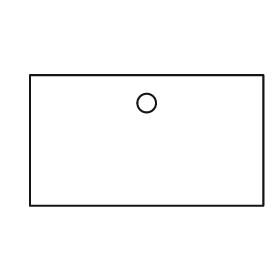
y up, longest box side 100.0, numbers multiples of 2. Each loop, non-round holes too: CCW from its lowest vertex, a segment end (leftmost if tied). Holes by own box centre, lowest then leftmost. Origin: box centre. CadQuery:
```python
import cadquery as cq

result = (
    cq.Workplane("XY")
    .moveTo(-50.0, -28.0)
    .lineTo(50.0, -28.0)
    .lineTo(50.0, 28.0)
    .lineTo(-50.0, 28.0)
    .close()
    .moveTo(0.0, 16.0)
    .circle(4.0)
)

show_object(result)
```